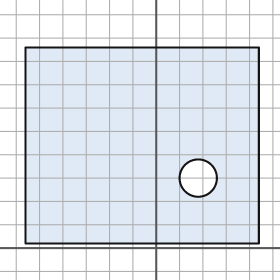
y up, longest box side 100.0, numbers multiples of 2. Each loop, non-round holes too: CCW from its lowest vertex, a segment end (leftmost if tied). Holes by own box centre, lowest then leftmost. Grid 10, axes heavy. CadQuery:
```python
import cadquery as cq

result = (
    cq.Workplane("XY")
    .moveTo(-56.0, 2.0)
    .lineTo(44.0, 2.0)
    .lineTo(44.0, 86.0)
    .lineTo(-56.0, 86.0)
    .close()
    .moveTo(18.0, 30.0)
    .circle(8.0)
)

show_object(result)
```